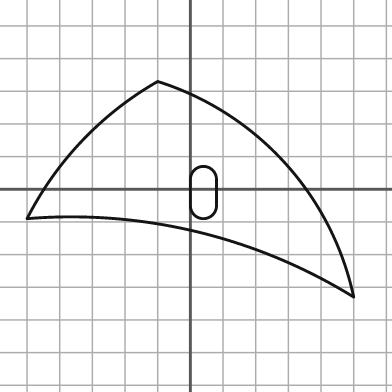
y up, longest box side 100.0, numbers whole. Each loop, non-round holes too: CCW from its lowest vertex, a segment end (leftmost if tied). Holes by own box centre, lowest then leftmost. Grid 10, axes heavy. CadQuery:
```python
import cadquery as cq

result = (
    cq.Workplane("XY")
    .moveTo(50.0, -33.0)
    .threePointArc((29.0, 8.0), (-10.0, 33.0))
    .threePointArc((-33.0, 15.0), (-50.0, -9.0))
    .threePointArc((2.0, -13.0), (50.0, -33.0))
    .close()
    .moveTo(0.0, -5.0)
    .threePointArc((4.0, -9.0), (8.0, -5.0))
    .lineTo(8.0, 3.0)
    .threePointArc((4.0, 7.0), (0.0, 3.0))
    .close()
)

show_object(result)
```